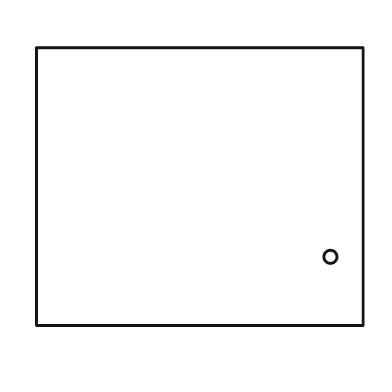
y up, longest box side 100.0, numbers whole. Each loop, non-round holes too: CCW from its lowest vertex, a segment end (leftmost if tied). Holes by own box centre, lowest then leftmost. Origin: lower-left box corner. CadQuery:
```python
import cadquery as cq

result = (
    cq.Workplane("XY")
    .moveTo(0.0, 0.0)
    .lineTo(100.0, 0.0)
    .lineTo(100.0, 85.0)
    .lineTo(0.0, 85.0)
    .close()
    .moveTo(90.0, 21.0)
    .circle(2.0)
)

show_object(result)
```